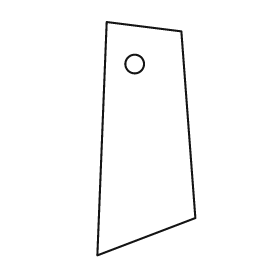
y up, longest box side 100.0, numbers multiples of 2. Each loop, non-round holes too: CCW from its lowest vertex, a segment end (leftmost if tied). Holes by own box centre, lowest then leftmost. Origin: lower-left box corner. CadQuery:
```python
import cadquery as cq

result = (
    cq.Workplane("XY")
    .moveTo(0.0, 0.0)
    .lineTo(42.0, 16.0)
    .lineTo(36.0, 96.0)
    .lineTo(4.0, 100.0)
    .close()
    .moveTo(16.0, 82.0)
    .circle(4.0)
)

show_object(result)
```